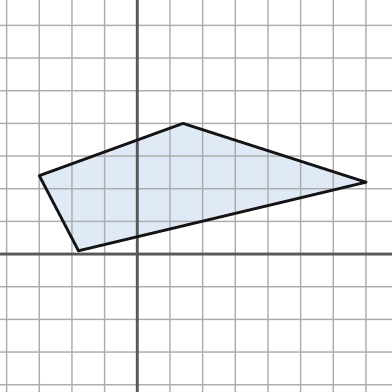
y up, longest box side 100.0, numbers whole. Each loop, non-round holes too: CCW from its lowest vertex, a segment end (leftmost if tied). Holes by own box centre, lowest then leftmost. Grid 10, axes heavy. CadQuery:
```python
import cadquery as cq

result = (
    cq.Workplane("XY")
    .moveTo(-18.0, 1.0)
    .lineTo(70.0, 22.0)
    .lineTo(14.0, 40.0)
    .lineTo(-30.0, 24.0)
    .close()
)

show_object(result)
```